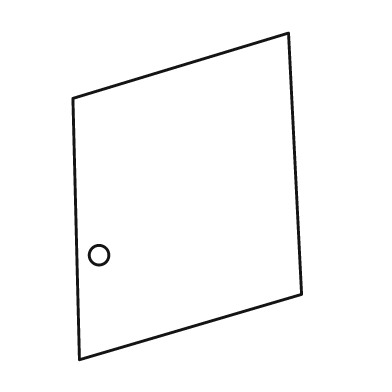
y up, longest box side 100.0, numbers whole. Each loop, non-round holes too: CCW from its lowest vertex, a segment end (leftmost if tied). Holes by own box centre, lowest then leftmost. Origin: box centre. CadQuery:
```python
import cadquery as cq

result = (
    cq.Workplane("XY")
    .moveTo(-33.0, -50.0)
    .lineTo(35.0, -30.0)
    .lineTo(31.0, 50.0)
    .lineTo(-35.0, 30.0)
    .close()
    .moveTo(-27.0, -18.0)
    .circle(3.0)
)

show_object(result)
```